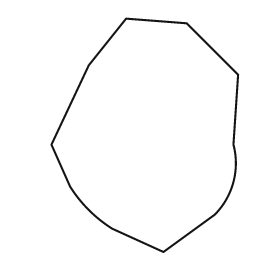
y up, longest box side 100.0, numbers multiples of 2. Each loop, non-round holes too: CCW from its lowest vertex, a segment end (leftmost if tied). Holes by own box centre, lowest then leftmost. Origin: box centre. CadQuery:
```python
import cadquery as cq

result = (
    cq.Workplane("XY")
    .moveTo(8.0, -50.0)
    .lineTo(30.0, -34.0)
    .threePointArc((38.0, -20.0), (38.0, -4.0))
    .lineTo(40.0, 26.0)
    .lineTo(18.0, 48.0)
    .lineTo(-8.0, 50.0)
    .lineTo(-24.0, 30.0)
    .lineTo(-40.0, -4.0)
    .lineTo(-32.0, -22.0)
    .threePointArc((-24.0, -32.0), (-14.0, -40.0))
    .close()
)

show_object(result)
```